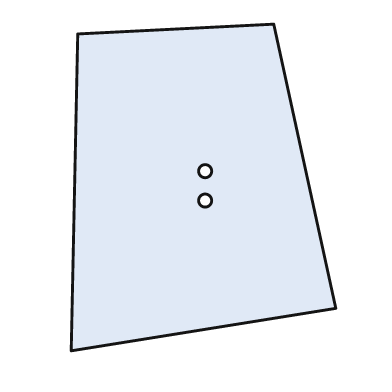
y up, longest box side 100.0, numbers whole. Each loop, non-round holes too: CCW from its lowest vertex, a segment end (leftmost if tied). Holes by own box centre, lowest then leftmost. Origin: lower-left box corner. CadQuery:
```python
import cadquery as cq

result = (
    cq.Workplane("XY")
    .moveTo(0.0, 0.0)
    .lineTo(81.0, 13.0)
    .lineTo(62.0, 100.0)
    .lineTo(2.0, 97.0)
    .close()
    .moveTo(41.0, 46.0)
    .circle(2.0)
    .moveTo(41.0, 55.0)
    .circle(2.0)
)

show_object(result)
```